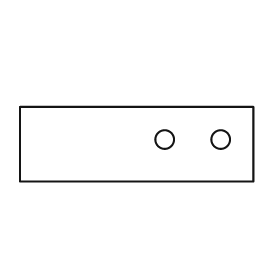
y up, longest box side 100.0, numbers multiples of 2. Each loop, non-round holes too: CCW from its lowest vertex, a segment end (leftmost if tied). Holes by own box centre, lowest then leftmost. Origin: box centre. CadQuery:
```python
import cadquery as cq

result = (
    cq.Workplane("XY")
    .moveTo(-50.0, -16.0)
    .lineTo(50.0, -16.0)
    .lineTo(50.0, 16.0)
    .lineTo(-50.0, 16.0)
    .close()
    .moveTo(12.0, 2.0)
    .circle(4.0)
    .moveTo(36.0, 2.0)
    .circle(4.0)
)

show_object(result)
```